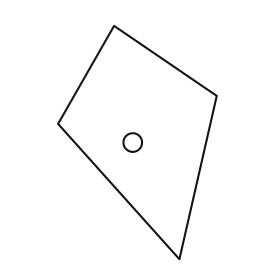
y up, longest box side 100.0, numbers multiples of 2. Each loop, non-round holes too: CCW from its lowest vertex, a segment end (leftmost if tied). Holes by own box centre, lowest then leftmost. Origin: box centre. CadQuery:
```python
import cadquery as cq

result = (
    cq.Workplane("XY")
    .moveTo(18.0, -50.0)
    .lineTo(34.0, 20.0)
    .lineTo(-10.0, 50.0)
    .lineTo(-34.0, 8.0)
    .close()
    .moveTo(-2.0, 0.0)
    .circle(4.0)
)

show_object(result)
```